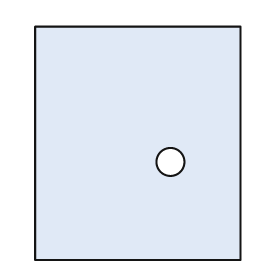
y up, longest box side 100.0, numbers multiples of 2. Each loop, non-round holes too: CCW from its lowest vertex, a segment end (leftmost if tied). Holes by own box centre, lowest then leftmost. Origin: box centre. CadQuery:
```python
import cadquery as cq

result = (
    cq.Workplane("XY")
    .moveTo(-44.0, -50.0)
    .lineTo(44.0, -50.0)
    .lineTo(44.0, 50.0)
    .lineTo(-44.0, 50.0)
    .close()
    .moveTo(14.0, -8.0)
    .circle(6.0)
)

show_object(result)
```